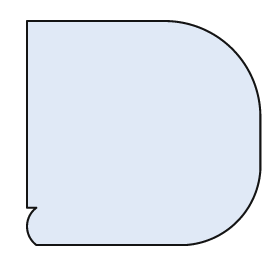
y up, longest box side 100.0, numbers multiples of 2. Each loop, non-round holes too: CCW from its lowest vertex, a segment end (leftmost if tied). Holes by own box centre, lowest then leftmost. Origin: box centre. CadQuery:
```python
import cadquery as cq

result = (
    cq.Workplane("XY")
    .moveTo(-46.0, -48.0)
    .lineTo(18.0, -48.0)
    .threePointArc((40.0, -38.0), (50.0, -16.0))
    .lineTo(50.0, 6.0)
    .threePointArc((38.0, 36.0), (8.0, 48.0))
    .lineTo(-50.0, 48.0)
    .lineTo(-50.0, -32.0)
    .lineTo(-46.0, -32.0)
    .threePointArc((-50.0, -40.0), (-46.0, -48.0))
    .close()
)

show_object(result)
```